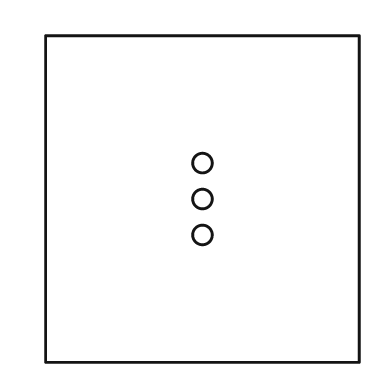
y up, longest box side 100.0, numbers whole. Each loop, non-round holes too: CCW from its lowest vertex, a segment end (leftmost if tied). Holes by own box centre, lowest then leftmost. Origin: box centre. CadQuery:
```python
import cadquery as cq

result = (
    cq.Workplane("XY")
    .moveTo(-48.0, -50.0)
    .lineTo(48.0, -50.0)
    .lineTo(48.0, 50.0)
    .lineTo(-48.0, 50.0)
    .close()
    .moveTo(0.0, -11.0)
    .circle(3.0)
    .moveTo(0.0, 0.0)
    .circle(3.0)
    .moveTo(0.0, 11.0)
    .circle(3.0)
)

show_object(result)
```